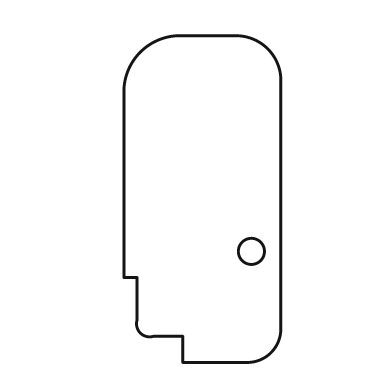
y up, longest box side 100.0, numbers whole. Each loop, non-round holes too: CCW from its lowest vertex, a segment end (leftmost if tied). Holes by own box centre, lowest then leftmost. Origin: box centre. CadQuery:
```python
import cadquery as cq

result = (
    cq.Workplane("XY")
    .moveTo(-6.0, -50.0)
    .lineTo(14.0, -50.0)
    .threePointArc((21.0, -47.0), (24.0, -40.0))
    .lineTo(24.0, 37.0)
    .threePointArc((20.0, 46.0), (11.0, 50.0))
    .lineTo(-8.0, 50.0)
    .threePointArc((-19.0, 45.0), (-24.0, 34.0))
    .lineTo(-24.0, -24.0)
    .lineTo(-20.0, -24.0)
    .lineTo(-20.0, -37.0)
    .threePointArc((-19.0, -41.0), (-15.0, -42.0))
    .lineTo(-6.0, -42.0)
    .close()
    .moveTo(15.0, -16.0)
    .circle(4.0)
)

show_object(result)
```